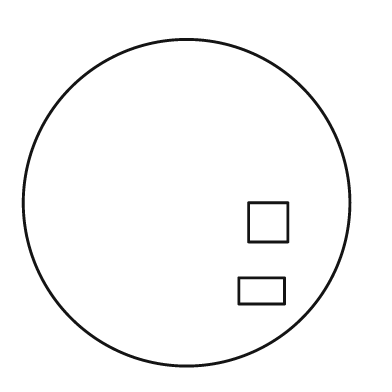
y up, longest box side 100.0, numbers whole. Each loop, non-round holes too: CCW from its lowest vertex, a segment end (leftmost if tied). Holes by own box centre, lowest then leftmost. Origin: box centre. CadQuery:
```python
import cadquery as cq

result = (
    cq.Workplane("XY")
    .moveTo(0.0, 0.0)
    .circle(50.0)
    .moveTo(16.0, -31.0)
    .lineTo(30.0, -31.0)
    .lineTo(30.0, -23.0)
    .lineTo(16.0, -23.0)
    .close()
    .moveTo(19.0, -12.0)
    .lineTo(31.0, -12.0)
    .lineTo(31.0, 0.0)
    .lineTo(19.0, 0.0)
    .close()
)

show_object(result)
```